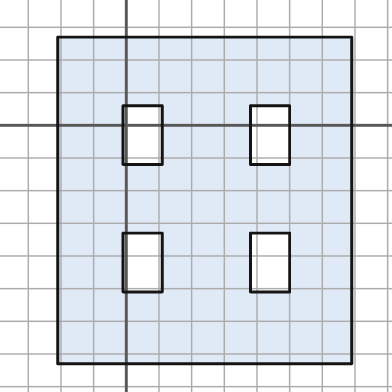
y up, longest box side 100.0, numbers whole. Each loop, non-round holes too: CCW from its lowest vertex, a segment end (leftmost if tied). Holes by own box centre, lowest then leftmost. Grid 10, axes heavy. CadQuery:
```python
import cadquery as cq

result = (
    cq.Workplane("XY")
    .moveTo(-21.0, -73.0)
    .lineTo(69.0, -73.0)
    .lineTo(69.0, 27.0)
    .lineTo(-21.0, 27.0)
    .close()
    .moveTo(-1.0, -51.0)
    .lineTo(11.0, -51.0)
    .lineTo(11.0, -33.0)
    .lineTo(-1.0, -33.0)
    .close()
    .moveTo(38.0, -51.0)
    .lineTo(50.0, -51.0)
    .lineTo(50.0, -33.0)
    .lineTo(38.0, -33.0)
    .close()
    .moveTo(-1.0, -12.0)
    .lineTo(11.0, -12.0)
    .lineTo(11.0, 6.0)
    .lineTo(-1.0, 6.0)
    .close()
    .moveTo(38.0, -12.0)
    .lineTo(50.0, -12.0)
    .lineTo(50.0, 6.0)
    .lineTo(38.0, 6.0)
    .close()
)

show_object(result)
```